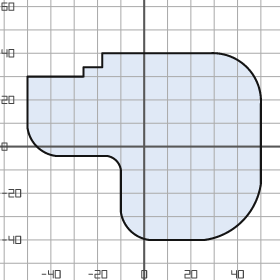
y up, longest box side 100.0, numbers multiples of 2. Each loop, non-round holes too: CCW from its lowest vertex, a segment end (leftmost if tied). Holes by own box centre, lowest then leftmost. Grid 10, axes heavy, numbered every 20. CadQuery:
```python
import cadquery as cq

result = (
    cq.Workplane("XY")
    .moveTo(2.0, -40.0)
    .lineTo(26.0, -40.0)
    .threePointArc((42.0, -32.0), (50.0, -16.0))
    .lineTo(50.0, 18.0)
    .threePointArc((44.0, 34.0), (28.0, 40.0))
    .lineTo(-18.0, 40.0)
    .lineTo(-18.0, 34.0)
    .lineTo(-26.0, 34.0)
    .lineTo(-26.0, 30.0)
    .lineTo(-50.0, 30.0)
    .lineTo(-50.0, 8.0)
    .threePointArc((-46.0, 0.0), (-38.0, -4.0))
    .lineTo(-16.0, -4.0)
    .threePointArc((-12.0, -6.0), (-10.0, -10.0))
    .lineTo(-10.0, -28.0)
    .threePointArc((-6.0, -36.0), (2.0, -40.0))
    .close()
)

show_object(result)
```